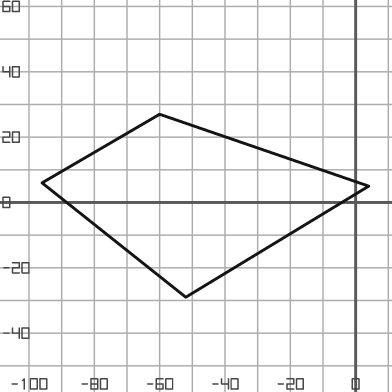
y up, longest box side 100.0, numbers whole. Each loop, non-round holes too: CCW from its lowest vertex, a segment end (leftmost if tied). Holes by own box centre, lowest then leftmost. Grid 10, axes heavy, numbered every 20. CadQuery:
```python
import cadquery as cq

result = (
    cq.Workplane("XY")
    .moveTo(-52.0, -29.0)
    .lineTo(4.0, 5.0)
    .lineTo(-60.0, 27.0)
    .lineTo(-96.0, 6.0)
    .close()
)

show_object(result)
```